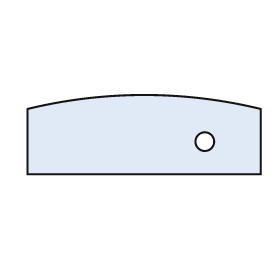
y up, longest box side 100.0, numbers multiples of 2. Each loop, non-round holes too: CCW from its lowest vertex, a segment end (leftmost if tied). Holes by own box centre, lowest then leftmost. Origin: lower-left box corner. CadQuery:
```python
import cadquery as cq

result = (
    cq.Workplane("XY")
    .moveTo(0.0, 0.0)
    .lineTo(100.0, 0.0)
    .lineTo(100.0, 28.0)
    .threePointArc((50.0, 34.0), (0.0, 28.0))
    .close()
    .moveTo(76.0, 14.0)
    .circle(4.0)
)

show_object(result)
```